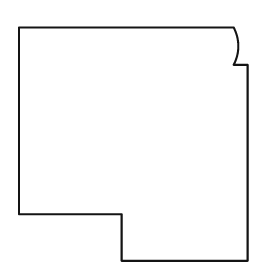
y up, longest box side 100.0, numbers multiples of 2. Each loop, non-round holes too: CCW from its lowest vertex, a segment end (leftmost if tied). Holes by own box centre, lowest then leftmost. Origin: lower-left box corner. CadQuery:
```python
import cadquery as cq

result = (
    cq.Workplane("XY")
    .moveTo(44.0, 0.0)
    .lineTo(98.0, 0.0)
    .lineTo(98.0, 84.0)
    .lineTo(92.0, 84.0)
    .threePointArc((94.0, 92.0), (92.0, 100.0))
    .lineTo(0.0, 100.0)
    .lineTo(0.0, 20.0)
    .lineTo(44.0, 20.0)
    .close()
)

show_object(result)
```